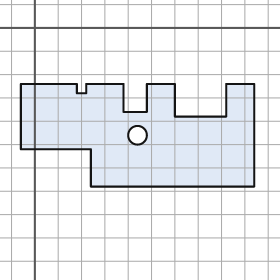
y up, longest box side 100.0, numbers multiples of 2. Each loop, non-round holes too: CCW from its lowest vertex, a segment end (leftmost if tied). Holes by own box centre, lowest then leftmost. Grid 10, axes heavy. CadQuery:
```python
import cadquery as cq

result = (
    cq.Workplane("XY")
    .moveTo(24.0, -68.0)
    .lineTo(94.0, -68.0)
    .lineTo(94.0, -24.0)
    .lineTo(82.0, -24.0)
    .lineTo(82.0, -38.0)
    .lineTo(60.0, -38.0)
    .lineTo(60.0, -24.0)
    .lineTo(48.0, -24.0)
    .lineTo(48.0, -36.0)
    .lineTo(38.0, -36.0)
    .lineTo(38.0, -24.0)
    .lineTo(22.0, -24.0)
    .lineTo(22.0, -28.0)
    .lineTo(18.0, -28.0)
    .lineTo(18.0, -24.0)
    .lineTo(-6.0, -24.0)
    .lineTo(-6.0, -52.0)
    .lineTo(24.0, -52.0)
    .close()
    .moveTo(44.0, -46.0)
    .circle(4.0)
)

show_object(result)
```